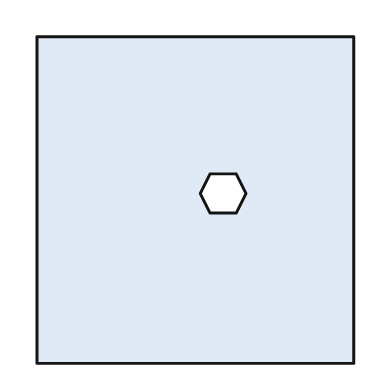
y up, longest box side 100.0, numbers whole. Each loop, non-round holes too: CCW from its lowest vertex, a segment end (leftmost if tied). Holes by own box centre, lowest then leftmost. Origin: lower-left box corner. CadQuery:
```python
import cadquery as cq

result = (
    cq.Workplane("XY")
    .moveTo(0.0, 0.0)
    .lineTo(97.0, 0.0)
    .lineTo(97.0, 100.0)
    .lineTo(0.0, 100.0)
    .close()
    .moveTo(53.0, 46.0)
    .lineTo(61.0, 46.0)
    .lineTo(64.0, 52.0)
    .lineTo(61.0, 58.0)
    .lineTo(53.0, 58.0)
    .lineTo(50.0, 52.0)
    .close()
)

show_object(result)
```